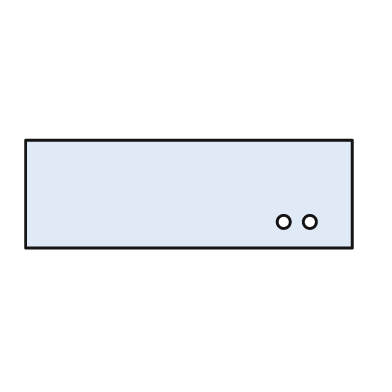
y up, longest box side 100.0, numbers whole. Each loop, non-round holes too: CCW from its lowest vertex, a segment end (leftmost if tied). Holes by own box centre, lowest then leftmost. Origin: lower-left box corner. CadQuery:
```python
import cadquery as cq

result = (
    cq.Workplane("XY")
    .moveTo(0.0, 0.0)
    .lineTo(100.0, 0.0)
    .lineTo(100.0, 33.0)
    .lineTo(0.0, 33.0)
    .close()
    .moveTo(79.0, 8.0)
    .circle(2.0)
    .moveTo(87.0, 8.0)
    .circle(2.0)
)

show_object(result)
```